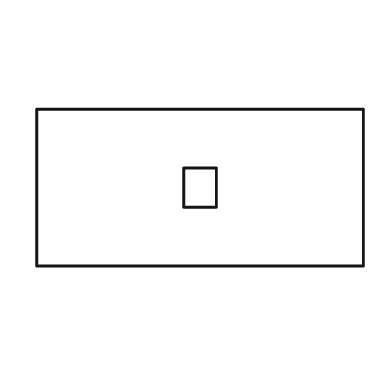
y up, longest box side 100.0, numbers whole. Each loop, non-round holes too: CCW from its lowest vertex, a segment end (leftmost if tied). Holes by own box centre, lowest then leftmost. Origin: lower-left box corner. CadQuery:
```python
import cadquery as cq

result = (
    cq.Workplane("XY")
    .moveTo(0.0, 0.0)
    .lineTo(100.0, 0.0)
    .lineTo(100.0, 48.0)
    .lineTo(0.0, 48.0)
    .close()
    .moveTo(45.0, 18.0)
    .lineTo(55.0, 18.0)
    .lineTo(55.0, 30.0)
    .lineTo(45.0, 30.0)
    .close()
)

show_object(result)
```